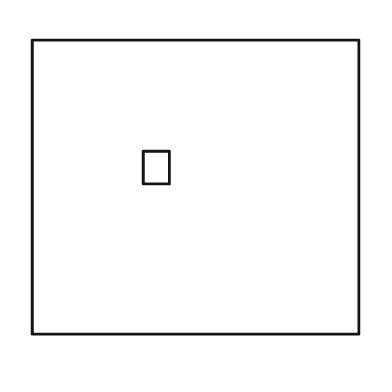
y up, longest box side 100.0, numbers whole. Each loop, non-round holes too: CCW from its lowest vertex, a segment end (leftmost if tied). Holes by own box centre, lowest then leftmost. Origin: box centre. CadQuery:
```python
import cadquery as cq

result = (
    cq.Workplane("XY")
    .moveTo(-50.0, -45.0)
    .lineTo(50.0, -45.0)
    .lineTo(50.0, 45.0)
    .lineTo(-50.0, 45.0)
    .close()
    .moveTo(-16.0, 1.0)
    .lineTo(-8.0, 1.0)
    .lineTo(-8.0, 11.0)
    .lineTo(-16.0, 11.0)
    .close()
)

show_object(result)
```